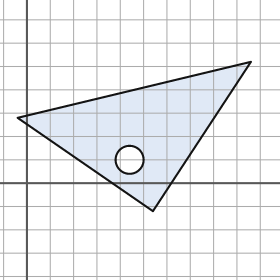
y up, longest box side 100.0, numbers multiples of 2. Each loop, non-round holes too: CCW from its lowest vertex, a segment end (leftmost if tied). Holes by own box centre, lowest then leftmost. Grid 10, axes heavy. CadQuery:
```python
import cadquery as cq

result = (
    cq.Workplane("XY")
    .moveTo(54.0, -12.0)
    .lineTo(96.0, 52.0)
    .lineTo(-4.0, 28.0)
    .close()
    .moveTo(44.0, 10.0)
    .circle(6.0)
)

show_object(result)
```